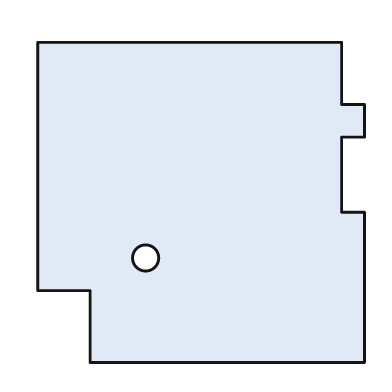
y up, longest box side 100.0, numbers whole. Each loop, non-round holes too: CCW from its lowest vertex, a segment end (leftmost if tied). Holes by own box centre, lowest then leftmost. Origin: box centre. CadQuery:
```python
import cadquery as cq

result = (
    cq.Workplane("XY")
    .moveTo(-34.0, -49.0)
    .lineTo(50.0, -49.0)
    .lineTo(50.0, -3.0)
    .lineTo(43.0, -3.0)
    .lineTo(43.0, 20.0)
    .lineTo(50.0, 20.0)
    .lineTo(50.0, 30.0)
    .lineTo(43.0, 30.0)
    .lineTo(43.0, 49.0)
    .lineTo(-50.0, 49.0)
    .lineTo(-50.0, -27.0)
    .lineTo(-34.0, -27.0)
    .close()
    .moveTo(-17.0, -17.0)
    .circle(4.0)
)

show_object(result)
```